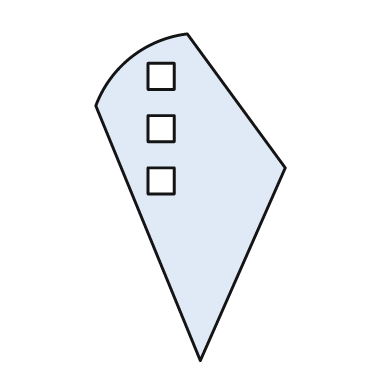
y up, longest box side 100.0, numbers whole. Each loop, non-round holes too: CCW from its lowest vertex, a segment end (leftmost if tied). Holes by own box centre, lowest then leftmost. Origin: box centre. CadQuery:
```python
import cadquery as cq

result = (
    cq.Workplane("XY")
    .moveTo(3.0, -50.0)
    .lineTo(29.0, 9.0)
    .lineTo(-1.0, 50.0)
    .threePointArc((-18.0, 43.0), (-29.0, 28.0))
    .close()
    .moveTo(-13.0, 1.0)
    .lineTo(-5.0, 1.0)
    .lineTo(-5.0, 9.0)
    .lineTo(-13.0, 9.0)
    .close()
    .moveTo(-13.0, 17.0)
    .lineTo(-5.0, 17.0)
    .lineTo(-5.0, 25.0)
    .lineTo(-13.0, 25.0)
    .close()
    .moveTo(-13.0, 33.0)
    .lineTo(-5.0, 33.0)
    .lineTo(-5.0, 41.0)
    .lineTo(-13.0, 41.0)
    .close()
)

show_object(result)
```